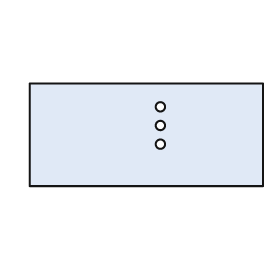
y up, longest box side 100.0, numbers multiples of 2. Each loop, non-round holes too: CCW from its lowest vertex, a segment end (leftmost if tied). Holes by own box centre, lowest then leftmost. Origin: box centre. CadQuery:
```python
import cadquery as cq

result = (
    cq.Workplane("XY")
    .moveTo(-50.0, -22.0)
    .lineTo(50.0, -22.0)
    .lineTo(50.0, 22.0)
    .lineTo(-50.0, 22.0)
    .close()
    .moveTo(6.0, -4.0)
    .circle(2.0)
    .moveTo(6.0, 4.0)
    .circle(2.0)
    .moveTo(6.0, 12.0)
    .circle(2.0)
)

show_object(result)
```